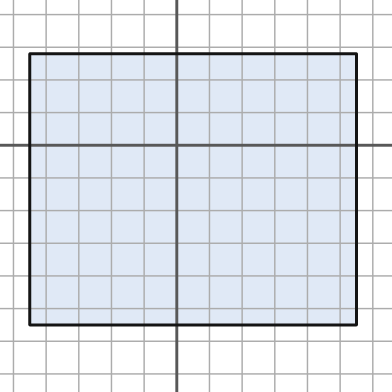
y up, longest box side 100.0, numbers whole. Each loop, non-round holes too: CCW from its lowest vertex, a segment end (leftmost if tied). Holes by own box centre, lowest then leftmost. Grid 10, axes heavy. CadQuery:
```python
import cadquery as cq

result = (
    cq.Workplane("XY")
    .moveTo(-45.0, -55.0)
    .lineTo(55.0, -55.0)
    .lineTo(55.0, 28.0)
    .lineTo(-45.0, 28.0)
    .close()
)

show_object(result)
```